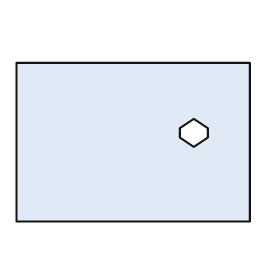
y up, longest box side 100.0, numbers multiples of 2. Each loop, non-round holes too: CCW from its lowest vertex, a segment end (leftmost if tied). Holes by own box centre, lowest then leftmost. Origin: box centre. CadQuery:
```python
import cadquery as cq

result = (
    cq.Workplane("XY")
    .moveTo(-50.0, -34.0)
    .lineTo(50.0, -34.0)
    .lineTo(50.0, 34.0)
    .lineTo(-50.0, 34.0)
    .close()
    .moveTo(26.0, -2.0)
    .lineTo(32.0, 2.0)
    .lineTo(32.0, 6.0)
    .lineTo(26.0, 10.0)
    .lineTo(20.0, 6.0)
    .lineTo(20.0, 2.0)
    .close()
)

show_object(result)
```